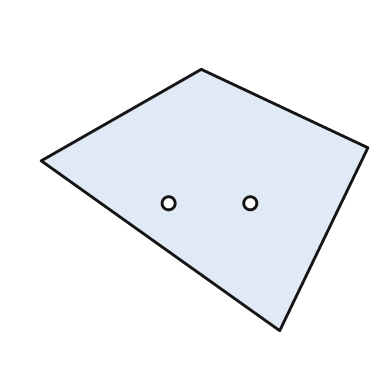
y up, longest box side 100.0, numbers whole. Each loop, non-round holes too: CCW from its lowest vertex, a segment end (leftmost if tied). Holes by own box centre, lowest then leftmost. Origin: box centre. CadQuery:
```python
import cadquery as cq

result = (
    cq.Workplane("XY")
    .moveTo(23.0, -40.0)
    .lineTo(50.0, 16.0)
    .lineTo(-1.0, 40.0)
    .lineTo(-50.0, 12.0)
    .close()
    .moveTo(-11.0, -1.0)
    .circle(2.0)
    .moveTo(14.0, -1.0)
    .circle(2.0)
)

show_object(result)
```